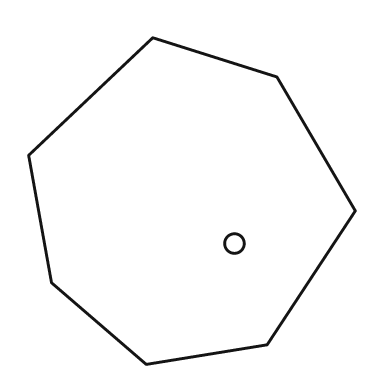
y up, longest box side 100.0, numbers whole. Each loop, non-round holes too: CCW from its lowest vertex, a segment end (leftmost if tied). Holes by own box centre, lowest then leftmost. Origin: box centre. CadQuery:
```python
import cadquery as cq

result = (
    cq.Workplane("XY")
    .moveTo(-14.0, -50.0)
    .lineTo(23.0, -44.0)
    .lineTo(50.0, -3.0)
    .lineTo(26.0, 38.0)
    .lineTo(-12.0, 50.0)
    .lineTo(-50.0, 14.0)
    .lineTo(-43.0, -25.0)
    .close()
    .moveTo(13.0, -13.0)
    .circle(3.0)
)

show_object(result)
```